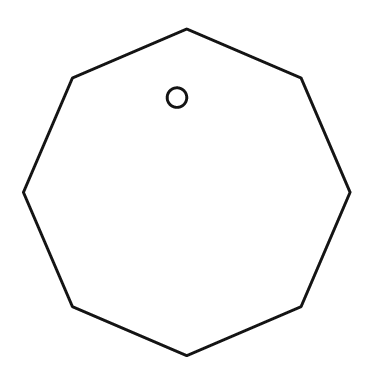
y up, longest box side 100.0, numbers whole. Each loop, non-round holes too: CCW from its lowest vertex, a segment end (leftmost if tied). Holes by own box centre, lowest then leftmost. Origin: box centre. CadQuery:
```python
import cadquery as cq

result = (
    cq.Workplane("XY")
    .moveTo(0.0, -50.0)
    .lineTo(35.0, -35.0)
    .lineTo(50.0, 0.0)
    .lineTo(35.0, 35.0)
    .lineTo(0.0, 50.0)
    .lineTo(-35.0, 35.0)
    .lineTo(-50.0, 0.0)
    .lineTo(-35.0, -35.0)
    .close()
    .moveTo(-3.0, 29.0)
    .circle(3.0)
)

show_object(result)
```